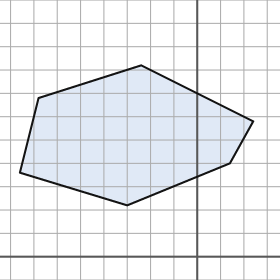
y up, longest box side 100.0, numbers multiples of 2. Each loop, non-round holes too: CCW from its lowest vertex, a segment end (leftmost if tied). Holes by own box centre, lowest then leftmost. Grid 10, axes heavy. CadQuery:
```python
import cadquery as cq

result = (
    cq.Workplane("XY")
    .moveTo(-30.0, 22.0)
    .lineTo(14.0, 40.0)
    .lineTo(24.0, 58.0)
    .lineTo(-24.0, 82.0)
    .lineTo(-68.0, 68.0)
    .lineTo(-76.0, 36.0)
    .close()
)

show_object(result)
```